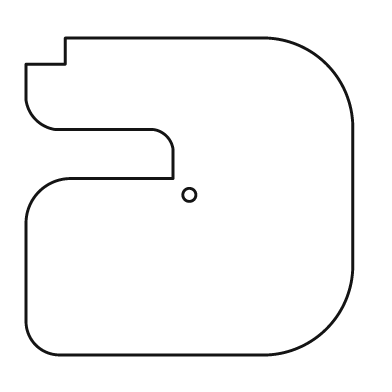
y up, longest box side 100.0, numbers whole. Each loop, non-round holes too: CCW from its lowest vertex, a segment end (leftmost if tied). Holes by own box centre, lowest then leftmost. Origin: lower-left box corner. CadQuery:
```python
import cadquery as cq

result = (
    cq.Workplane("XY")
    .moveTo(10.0, 0.0)
    .lineTo(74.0, 0.0)
    .threePointArc((92.0, 8.0), (100.0, 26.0))
    .lineTo(100.0, 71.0)
    .threePointArc((92.0, 89.0), (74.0, 97.0))
    .lineTo(12.0, 97.0)
    .lineTo(12.0, 89.0)
    .lineTo(0.0, 89.0)
    .lineTo(0.0, 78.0)
    .threePointArc((3.0, 72.0), (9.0, 69.0))
    .lineTo(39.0, 69.0)
    .threePointArc((43.0, 67.0), (45.0, 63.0))
    .lineTo(45.0, 54.0)
    .lineTo(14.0, 54.0)
    .threePointArc((4.0, 50.0), (0.0, 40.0))
    .lineTo(0.0, 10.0)
    .threePointArc((3.0, 3.0), (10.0, 0.0))
    .close()
    .moveTo(50.0, 49.0)
    .circle(2.0)
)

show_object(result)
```